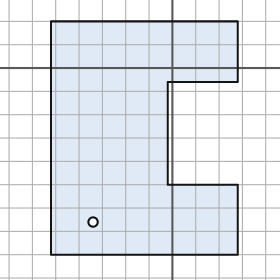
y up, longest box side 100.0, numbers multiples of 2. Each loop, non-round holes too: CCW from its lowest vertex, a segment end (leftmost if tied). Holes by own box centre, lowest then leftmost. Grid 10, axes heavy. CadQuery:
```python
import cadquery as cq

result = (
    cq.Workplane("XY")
    .moveTo(-52.0, -80.0)
    .lineTo(28.0, -80.0)
    .lineTo(28.0, -50.0)
    .lineTo(-2.0, -50.0)
    .lineTo(-2.0, -6.0)
    .lineTo(28.0, -6.0)
    .lineTo(28.0, 20.0)
    .lineTo(-52.0, 20.0)
    .close()
    .moveTo(-34.0, -66.0)
    .circle(2.0)
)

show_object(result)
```